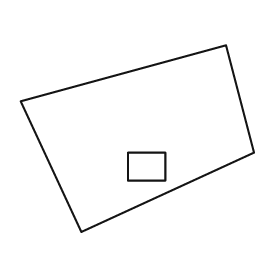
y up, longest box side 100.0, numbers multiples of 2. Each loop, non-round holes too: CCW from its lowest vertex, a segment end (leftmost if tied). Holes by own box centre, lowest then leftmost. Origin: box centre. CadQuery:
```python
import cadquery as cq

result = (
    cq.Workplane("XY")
    .moveTo(-24.0, -40.0)
    .lineTo(50.0, -6.0)
    .lineTo(38.0, 40.0)
    .lineTo(-50.0, 16.0)
    .close()
    .moveTo(-4.0, -18.0)
    .lineTo(12.0, -18.0)
    .lineTo(12.0, -6.0)
    .lineTo(-4.0, -6.0)
    .close()
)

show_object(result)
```